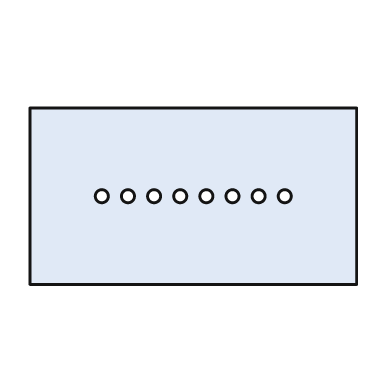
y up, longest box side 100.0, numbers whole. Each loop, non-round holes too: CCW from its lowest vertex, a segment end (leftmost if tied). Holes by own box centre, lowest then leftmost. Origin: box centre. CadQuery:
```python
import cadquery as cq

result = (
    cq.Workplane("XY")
    .moveTo(-50.0, -27.0)
    .lineTo(50.0, -27.0)
    .lineTo(50.0, 27.0)
    .lineTo(-50.0, 27.0)
    .close()
    .moveTo(-28.0, 0.0)
    .circle(2.0)
    .moveTo(-20.0, 0.0)
    .circle(2.0)
    .moveTo(-12.0, 0.0)
    .circle(2.0)
    .moveTo(-4.0, 0.0)
    .circle(2.0)
    .moveTo(4.0, 0.0)
    .circle(2.0)
    .moveTo(12.0, 0.0)
    .circle(2.0)
    .moveTo(20.0, 0.0)
    .circle(2.0)
    .moveTo(28.0, 0.0)
    .circle(2.0)
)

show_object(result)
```